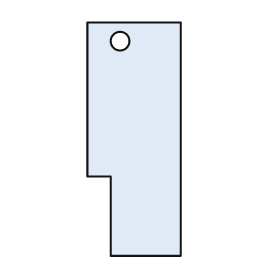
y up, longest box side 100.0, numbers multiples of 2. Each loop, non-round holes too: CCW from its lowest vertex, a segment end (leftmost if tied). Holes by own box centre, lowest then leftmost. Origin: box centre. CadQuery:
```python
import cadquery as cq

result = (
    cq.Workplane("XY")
    .moveTo(-10.0, -50.0)
    .lineTo(20.0, -50.0)
    .lineTo(20.0, 50.0)
    .lineTo(-20.0, 50.0)
    .lineTo(-20.0, -16.0)
    .lineTo(-10.0, -16.0)
    .close()
    .moveTo(-6.0, 42.0)
    .circle(4.0)
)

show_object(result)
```